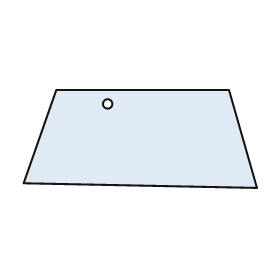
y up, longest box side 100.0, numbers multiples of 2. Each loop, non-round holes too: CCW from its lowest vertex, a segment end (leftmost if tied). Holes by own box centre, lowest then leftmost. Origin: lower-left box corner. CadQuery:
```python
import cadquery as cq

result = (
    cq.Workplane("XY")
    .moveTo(100.0, 0.0)
    .lineTo(88.0, 42.0)
    .lineTo(14.0, 42.0)
    .lineTo(0.0, 2.0)
    .close()
    .moveTo(36.0, 36.0)
    .circle(2.0)
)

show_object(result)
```